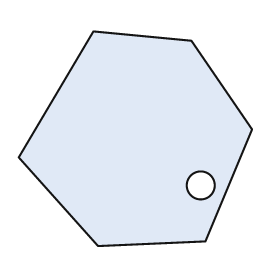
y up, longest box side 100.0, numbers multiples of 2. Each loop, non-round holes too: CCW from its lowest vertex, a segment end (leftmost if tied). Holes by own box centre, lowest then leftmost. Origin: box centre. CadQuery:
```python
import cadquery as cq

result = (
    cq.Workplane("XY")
    .moveTo(-16.0, -46.0)
    .lineTo(30.0, -44.0)
    .lineTo(50.0, 4.0)
    .lineTo(24.0, 42.0)
    .lineTo(-18.0, 46.0)
    .lineTo(-50.0, -8.0)
    .close()
    .moveTo(28.0, -20.0)
    .circle(6.0)
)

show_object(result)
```